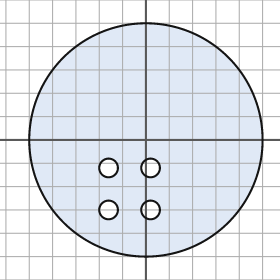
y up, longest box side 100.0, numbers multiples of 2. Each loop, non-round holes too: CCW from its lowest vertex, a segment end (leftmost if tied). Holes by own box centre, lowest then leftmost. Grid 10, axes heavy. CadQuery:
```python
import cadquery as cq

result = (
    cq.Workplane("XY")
    .moveTo(0.0, 0.0)
    .circle(50.0)
    .moveTo(-16.0, -30.0)
    .circle(4.0)
    .moveTo(2.0, -30.0)
    .circle(4.0)
    .moveTo(-16.0, -12.0)
    .circle(4.0)
    .moveTo(2.0, -12.0)
    .circle(4.0)
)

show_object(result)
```